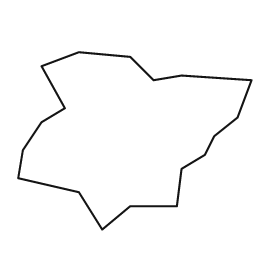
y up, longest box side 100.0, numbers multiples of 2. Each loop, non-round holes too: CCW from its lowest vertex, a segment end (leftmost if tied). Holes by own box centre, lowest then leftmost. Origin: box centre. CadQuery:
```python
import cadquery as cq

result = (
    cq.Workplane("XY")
    .moveTo(-14.0, -38.0)
    .lineTo(-2.0, -28.0)
    .lineTo(18.0, -28.0)
    .lineTo(20.0, -12.0)
    .lineTo(30.0, -6.0)
    .lineTo(34.0, 2.0)
    .lineTo(44.0, 10.0)
    .lineTo(50.0, 26.0)
    .lineTo(20.0, 28.0)
    .lineTo(8.0, 26.0)
    .lineTo(-2.0, 36.0)
    .lineTo(-24.0, 38.0)
    .lineTo(-40.0, 32.0)
    .lineTo(-30.0, 14.0)
    .lineTo(-40.0, 8.0)
    .lineTo(-48.0, -4.0)
    .lineTo(-50.0, -16.0)
    .lineTo(-24.0, -22.0)
    .close()
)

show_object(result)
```